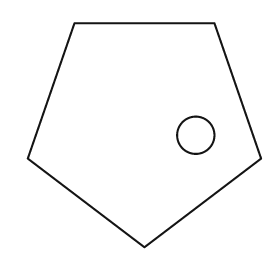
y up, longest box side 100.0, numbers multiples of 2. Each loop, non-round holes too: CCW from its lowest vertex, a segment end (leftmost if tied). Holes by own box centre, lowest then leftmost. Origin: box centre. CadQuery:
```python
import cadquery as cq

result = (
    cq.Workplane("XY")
    .moveTo(0.0, -48.0)
    .lineTo(50.0, -10.0)
    .lineTo(30.0, 48.0)
    .lineTo(-30.0, 48.0)
    .lineTo(-50.0, -10.0)
    .close()
    .moveTo(22.0, 0.0)
    .circle(8.0)
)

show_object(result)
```